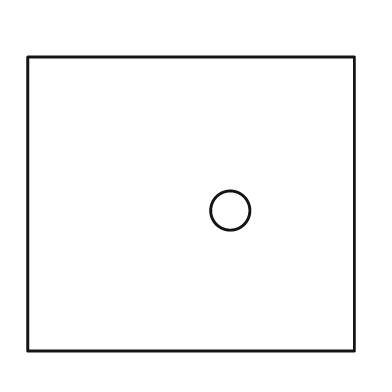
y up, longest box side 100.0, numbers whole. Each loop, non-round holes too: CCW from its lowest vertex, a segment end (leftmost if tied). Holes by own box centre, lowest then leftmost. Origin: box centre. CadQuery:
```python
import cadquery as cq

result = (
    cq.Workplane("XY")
    .moveTo(-50.0, -45.0)
    .lineTo(50.0, -45.0)
    .lineTo(50.0, 45.0)
    .lineTo(-50.0, 45.0)
    .close()
    .moveTo(12.0, -2.0)
    .circle(6.0)
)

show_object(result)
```